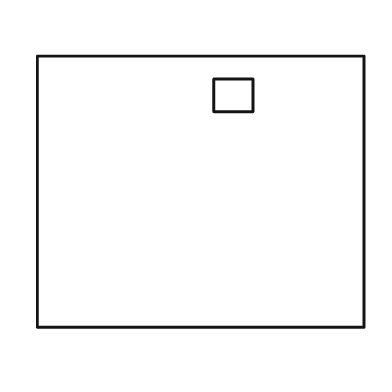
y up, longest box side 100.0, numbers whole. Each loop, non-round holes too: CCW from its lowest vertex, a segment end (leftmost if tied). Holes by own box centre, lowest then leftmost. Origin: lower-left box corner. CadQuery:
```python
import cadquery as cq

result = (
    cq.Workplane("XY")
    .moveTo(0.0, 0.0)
    .lineTo(100.0, 0.0)
    .lineTo(100.0, 83.0)
    .lineTo(0.0, 83.0)
    .close()
    .moveTo(54.0, 66.0)
    .lineTo(66.0, 66.0)
    .lineTo(66.0, 76.0)
    .lineTo(54.0, 76.0)
    .close()
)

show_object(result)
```